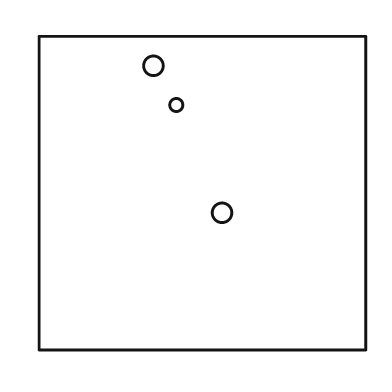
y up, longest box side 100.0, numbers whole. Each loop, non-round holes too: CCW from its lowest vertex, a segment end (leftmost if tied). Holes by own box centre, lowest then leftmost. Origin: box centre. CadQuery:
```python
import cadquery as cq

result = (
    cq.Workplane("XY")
    .moveTo(-50.0, -48.0)
    .lineTo(50.0, -48.0)
    .lineTo(50.0, 48.0)
    .lineTo(-50.0, 48.0)
    .close()
    .moveTo(6.0, -6.0)
    .circle(3.0)
    .moveTo(-8.0, 27.0)
    .circle(2.0)
    .moveTo(-15.0, 39.0)
    .circle(3.0)
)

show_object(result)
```